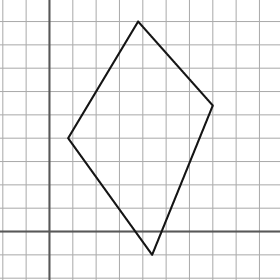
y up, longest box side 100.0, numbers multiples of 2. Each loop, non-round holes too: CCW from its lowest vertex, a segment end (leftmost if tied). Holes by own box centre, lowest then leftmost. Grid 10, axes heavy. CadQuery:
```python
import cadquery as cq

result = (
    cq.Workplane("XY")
    .moveTo(44.0, -10.0)
    .lineTo(70.0, 54.0)
    .lineTo(38.0, 90.0)
    .lineTo(8.0, 40.0)
    .close()
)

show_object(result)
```